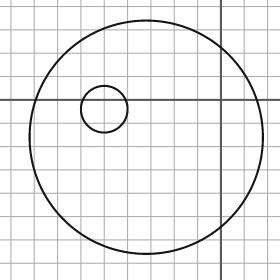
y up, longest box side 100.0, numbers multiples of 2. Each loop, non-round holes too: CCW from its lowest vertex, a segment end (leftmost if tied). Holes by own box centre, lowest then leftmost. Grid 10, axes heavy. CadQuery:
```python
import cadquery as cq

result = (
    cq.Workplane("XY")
    .moveTo(-32.0, -16.0)
    .circle(50.0)
    .moveTo(-50.0, -4.0)
    .circle(10.0)
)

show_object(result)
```